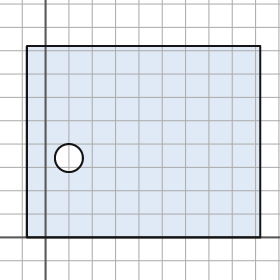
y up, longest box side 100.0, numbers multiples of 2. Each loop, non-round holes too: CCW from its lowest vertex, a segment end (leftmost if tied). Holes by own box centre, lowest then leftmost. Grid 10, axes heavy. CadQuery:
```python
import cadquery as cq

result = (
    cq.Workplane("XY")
    .moveTo(-8.0, 0.0)
    .lineTo(92.0, 0.0)
    .lineTo(92.0, 82.0)
    .lineTo(-8.0, 82.0)
    .close()
    .moveTo(10.0, 34.0)
    .circle(6.0)
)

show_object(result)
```